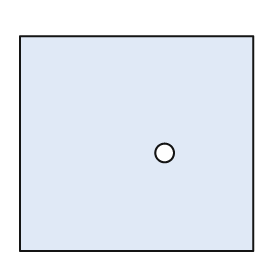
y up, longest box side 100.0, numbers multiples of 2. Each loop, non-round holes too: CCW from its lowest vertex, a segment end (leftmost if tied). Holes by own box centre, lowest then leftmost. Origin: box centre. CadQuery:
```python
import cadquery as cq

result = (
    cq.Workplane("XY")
    .moveTo(-50.0, -46.0)
    .lineTo(50.0, -46.0)
    .lineTo(50.0, 46.0)
    .lineTo(-50.0, 46.0)
    .close()
    .moveTo(12.0, -4.0)
    .circle(4.0)
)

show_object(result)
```